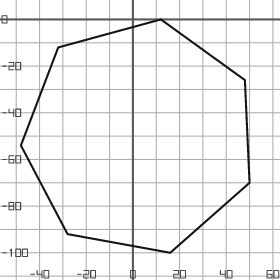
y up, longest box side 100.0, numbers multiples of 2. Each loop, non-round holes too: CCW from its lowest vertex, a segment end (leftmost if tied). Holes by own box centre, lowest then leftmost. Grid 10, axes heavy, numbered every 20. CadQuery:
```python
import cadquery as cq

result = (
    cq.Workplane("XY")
    .moveTo(16.0, -100.0)
    .lineTo(50.0, -70.0)
    .lineTo(48.0, -26.0)
    .lineTo(12.0, 0.0)
    .lineTo(-32.0, -12.0)
    .lineTo(-48.0, -54.0)
    .lineTo(-28.0, -92.0)
    .close()
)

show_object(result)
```